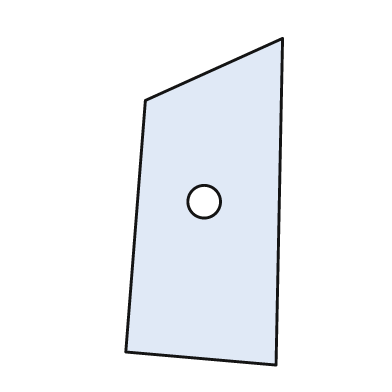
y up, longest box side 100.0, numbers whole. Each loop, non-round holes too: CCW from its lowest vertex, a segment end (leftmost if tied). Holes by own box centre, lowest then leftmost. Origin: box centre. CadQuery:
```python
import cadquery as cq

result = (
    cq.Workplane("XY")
    .moveTo(22.0, -50.0)
    .lineTo(24.0, 50.0)
    .lineTo(-18.0, 31.0)
    .lineTo(-24.0, -46.0)
    .close()
    .moveTo(0.0, 0.0)
    .circle(5.0)
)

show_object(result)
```